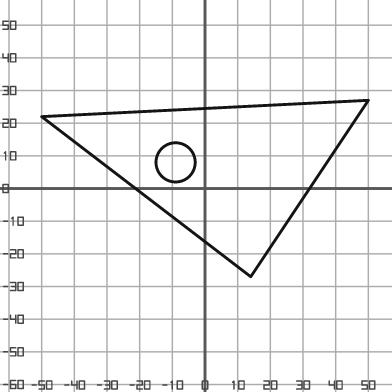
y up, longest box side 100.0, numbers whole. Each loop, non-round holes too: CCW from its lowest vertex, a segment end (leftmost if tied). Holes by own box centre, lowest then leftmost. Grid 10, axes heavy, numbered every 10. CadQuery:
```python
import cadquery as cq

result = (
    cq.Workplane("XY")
    .moveTo(14.0, -27.0)
    .lineTo(50.0, 27.0)
    .lineTo(-50.0, 22.0)
    .close()
    .moveTo(-9.0, 8.0)
    .circle(6.0)
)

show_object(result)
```